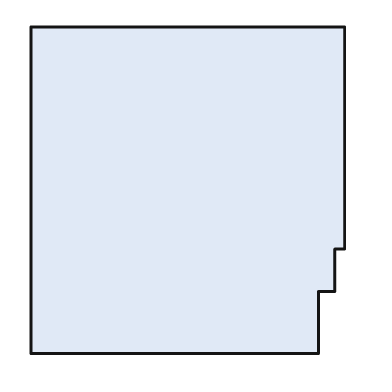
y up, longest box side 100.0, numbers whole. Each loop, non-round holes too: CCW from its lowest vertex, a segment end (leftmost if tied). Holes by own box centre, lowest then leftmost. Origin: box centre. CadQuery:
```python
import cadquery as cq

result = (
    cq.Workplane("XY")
    .moveTo(-48.0, -50.0)
    .lineTo(40.0, -50.0)
    .lineTo(40.0, -31.0)
    .lineTo(45.0, -31.0)
    .lineTo(45.0, -18.0)
    .lineTo(48.0, -18.0)
    .lineTo(48.0, 50.0)
    .lineTo(-48.0, 50.0)
    .close()
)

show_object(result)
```